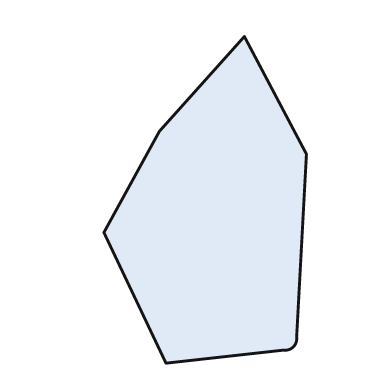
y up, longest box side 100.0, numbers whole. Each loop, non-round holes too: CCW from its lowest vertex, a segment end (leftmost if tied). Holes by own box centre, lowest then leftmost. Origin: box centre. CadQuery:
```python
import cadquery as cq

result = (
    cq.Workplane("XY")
    .moveTo(-12.0, -50.0)
    .lineTo(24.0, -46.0)
    .threePointArc((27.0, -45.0), (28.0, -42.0))
    .lineTo(31.0, 14.0)
    .lineTo(12.0, 50.0)
    .lineTo(-14.0, 21.0)
    .lineTo(-31.0, -10.0)
    .close()
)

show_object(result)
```